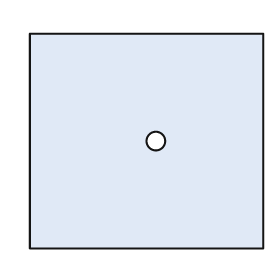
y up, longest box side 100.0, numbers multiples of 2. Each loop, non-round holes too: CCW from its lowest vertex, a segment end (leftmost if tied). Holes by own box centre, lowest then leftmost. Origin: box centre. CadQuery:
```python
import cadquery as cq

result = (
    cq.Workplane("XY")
    .moveTo(-50.0, -46.0)
    .lineTo(50.0, -46.0)
    .lineTo(50.0, 46.0)
    .lineTo(-50.0, 46.0)
    .close()
    .moveTo(4.0, 0.0)
    .circle(4.0)
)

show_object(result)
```